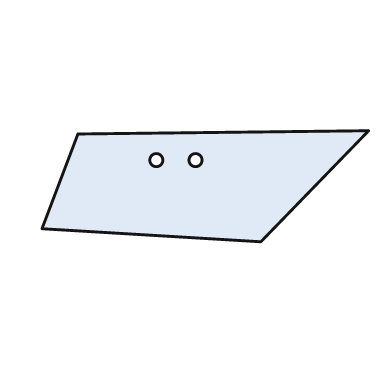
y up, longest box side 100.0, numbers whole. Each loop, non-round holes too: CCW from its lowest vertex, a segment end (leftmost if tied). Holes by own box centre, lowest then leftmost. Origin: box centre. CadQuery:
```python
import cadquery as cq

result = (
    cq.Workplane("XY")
    .moveTo(17.0, -17.0)
    .lineTo(50.0, 17.0)
    .lineTo(-39.0, 16.0)
    .lineTo(-50.0, -13.0)
    .close()
    .moveTo(-15.0, 8.0)
    .circle(2.0)
    .moveTo(-3.0, 8.0)
    .circle(2.0)
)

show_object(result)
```